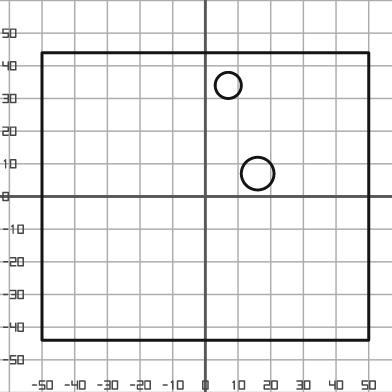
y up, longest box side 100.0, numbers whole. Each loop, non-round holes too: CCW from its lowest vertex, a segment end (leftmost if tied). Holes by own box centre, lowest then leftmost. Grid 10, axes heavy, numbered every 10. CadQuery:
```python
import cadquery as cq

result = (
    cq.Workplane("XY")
    .moveTo(-50.0, -44.0)
    .lineTo(50.0, -44.0)
    .lineTo(50.0, 44.0)
    .lineTo(-50.0, 44.0)
    .close()
    .moveTo(16.0, 7.0)
    .circle(5.0)
    .moveTo(7.0, 34.0)
    .circle(4.0)
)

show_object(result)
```